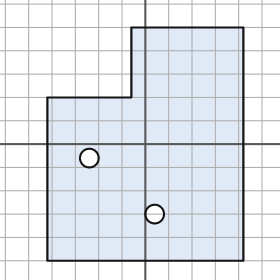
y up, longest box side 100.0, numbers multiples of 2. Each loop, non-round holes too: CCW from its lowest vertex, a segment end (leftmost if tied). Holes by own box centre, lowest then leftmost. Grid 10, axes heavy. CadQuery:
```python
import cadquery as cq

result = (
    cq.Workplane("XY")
    .moveTo(-42.0, -50.0)
    .lineTo(42.0, -50.0)
    .lineTo(42.0, 50.0)
    .lineTo(-6.0, 50.0)
    .lineTo(-6.0, 20.0)
    .lineTo(-42.0, 20.0)
    .close()
    .moveTo(4.0, -30.0)
    .circle(4.0)
    .moveTo(-24.0, -6.0)
    .circle(4.0)
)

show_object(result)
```